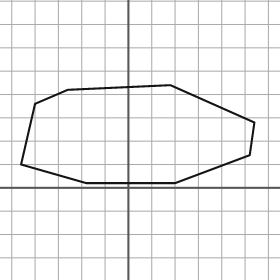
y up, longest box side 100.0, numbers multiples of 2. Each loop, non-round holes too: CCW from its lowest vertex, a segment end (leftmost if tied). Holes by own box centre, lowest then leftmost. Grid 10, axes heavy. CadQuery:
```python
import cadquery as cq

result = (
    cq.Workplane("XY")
    .moveTo(-18.0, 2.0)
    .lineTo(20.0, 2.0)
    .lineTo(52.0, 14.0)
    .lineTo(54.0, 28.0)
    .lineTo(18.0, 44.0)
    .lineTo(-26.0, 42.0)
    .lineTo(-40.0, 36.0)
    .lineTo(-46.0, 10.0)
    .close()
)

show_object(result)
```